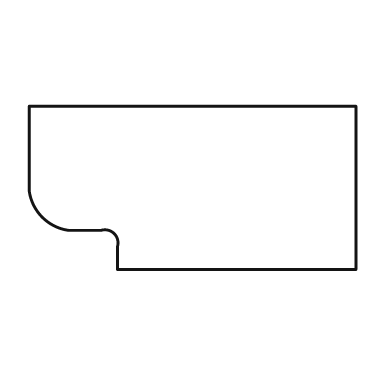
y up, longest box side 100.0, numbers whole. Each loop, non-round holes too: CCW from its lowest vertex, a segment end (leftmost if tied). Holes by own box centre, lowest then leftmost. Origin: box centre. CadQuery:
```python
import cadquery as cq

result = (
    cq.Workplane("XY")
    .moveTo(-23.0, -25.0)
    .lineTo(50.0, -25.0)
    .lineTo(50.0, 25.0)
    .lineTo(-50.0, 25.0)
    .lineTo(-50.0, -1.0)
    .threePointArc((-46.0, -9.0), (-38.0, -13.0))
    .lineTo(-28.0, -13.0)
    .threePointArc((-24.0, -14.0), (-23.0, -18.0))
    .close()
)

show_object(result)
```